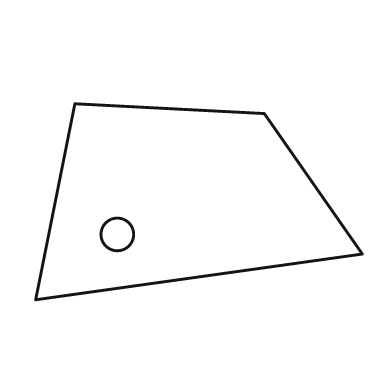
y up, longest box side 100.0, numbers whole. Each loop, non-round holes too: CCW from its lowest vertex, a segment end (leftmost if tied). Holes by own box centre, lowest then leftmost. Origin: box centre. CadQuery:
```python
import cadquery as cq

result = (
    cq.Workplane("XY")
    .moveTo(-50.0, -30.0)
    .lineTo(50.0, -16.0)
    .lineTo(20.0, 27.0)
    .lineTo(-38.0, 30.0)
    .close()
    .moveTo(-25.0, -10.0)
    .circle(5.0)
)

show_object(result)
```